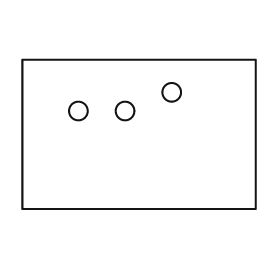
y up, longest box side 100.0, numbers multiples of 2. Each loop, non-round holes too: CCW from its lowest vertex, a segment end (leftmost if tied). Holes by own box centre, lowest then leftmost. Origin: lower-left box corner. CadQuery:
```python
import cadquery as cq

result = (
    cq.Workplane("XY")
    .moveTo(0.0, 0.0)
    .lineTo(100.0, 0.0)
    .lineTo(100.0, 64.0)
    .lineTo(0.0, 64.0)
    .close()
    .moveTo(24.0, 42.0)
    .circle(4.0)
    .moveTo(44.0, 42.0)
    .circle(4.0)
    .moveTo(64.0, 50.0)
    .circle(4.0)
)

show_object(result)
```